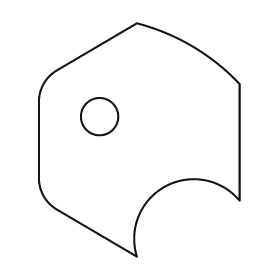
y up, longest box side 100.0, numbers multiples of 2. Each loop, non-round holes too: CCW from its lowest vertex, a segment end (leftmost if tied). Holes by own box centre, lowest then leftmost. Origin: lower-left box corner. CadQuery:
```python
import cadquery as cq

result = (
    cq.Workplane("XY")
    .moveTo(42.0, 0.0)
    .threePointArc((54.0, 30.0), (86.0, 24.0))
    .lineTo(86.0, 74.0)
    .threePointArc((66.0, 90.0), (42.0, 100.0))
    .lineTo(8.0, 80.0)
    .threePointArc((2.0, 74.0), (0.0, 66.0))
    .lineTo(0.0, 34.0)
    .threePointArc((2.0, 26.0), (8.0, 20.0))
    .close()
    .moveTo(26.0, 60.0)
    .circle(8.0)
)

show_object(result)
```